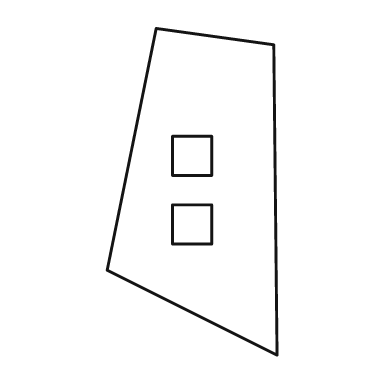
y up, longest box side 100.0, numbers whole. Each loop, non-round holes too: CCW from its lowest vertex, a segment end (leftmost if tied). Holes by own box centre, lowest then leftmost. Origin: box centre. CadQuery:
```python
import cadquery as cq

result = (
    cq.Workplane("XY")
    .moveTo(26.0, -50.0)
    .lineTo(25.0, 45.0)
    .lineTo(-11.0, 50.0)
    .lineTo(-26.0, -24.0)
    .close()
    .moveTo(-6.0, -16.0)
    .lineTo(6.0, -16.0)
    .lineTo(6.0, -4.0)
    .lineTo(-6.0, -4.0)
    .close()
    .moveTo(-6.0, 5.0)
    .lineTo(6.0, 5.0)
    .lineTo(6.0, 17.0)
    .lineTo(-6.0, 17.0)
    .close()
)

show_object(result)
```